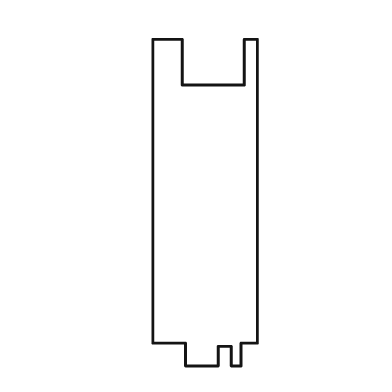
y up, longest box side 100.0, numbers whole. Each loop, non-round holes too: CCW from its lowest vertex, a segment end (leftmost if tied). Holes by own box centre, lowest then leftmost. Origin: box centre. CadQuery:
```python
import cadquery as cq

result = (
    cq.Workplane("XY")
    .moveTo(-6.0, -50.0)
    .lineTo(4.0, -50.0)
    .lineTo(4.0, -44.0)
    .lineTo(8.0, -44.0)
    .lineTo(8.0, -50.0)
    .lineTo(11.0, -50.0)
    .lineTo(11.0, -43.0)
    .lineTo(16.0, -43.0)
    .lineTo(16.0, 50.0)
    .lineTo(12.0, 50.0)
    .lineTo(12.0, 36.0)
    .lineTo(-7.0, 36.0)
    .lineTo(-7.0, 50.0)
    .lineTo(-16.0, 50.0)
    .lineTo(-16.0, -43.0)
    .lineTo(-6.0, -43.0)
    .close()
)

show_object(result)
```